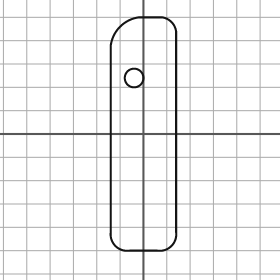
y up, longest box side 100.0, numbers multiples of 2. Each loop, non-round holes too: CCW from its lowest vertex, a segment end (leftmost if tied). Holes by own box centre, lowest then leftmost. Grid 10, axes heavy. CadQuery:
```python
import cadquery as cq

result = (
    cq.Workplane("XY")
    .moveTo(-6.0, -50.0)
    .lineTo(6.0, -50.0)
    .threePointArc((12.0, -48.0), (14.0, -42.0))
    .lineTo(14.0, 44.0)
    .threePointArc((12.0, 48.0), (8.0, 50.0))
    .lineTo(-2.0, 50.0)
    .threePointArc((-10.0, 46.0), (-14.0, 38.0))
    .lineTo(-14.0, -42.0)
    .threePointArc((-12.0, -48.0), (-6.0, -50.0))
    .close()
    .moveTo(-4.0, 24.0)
    .circle(4.0)
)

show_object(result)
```